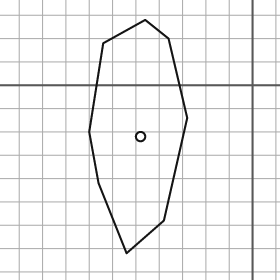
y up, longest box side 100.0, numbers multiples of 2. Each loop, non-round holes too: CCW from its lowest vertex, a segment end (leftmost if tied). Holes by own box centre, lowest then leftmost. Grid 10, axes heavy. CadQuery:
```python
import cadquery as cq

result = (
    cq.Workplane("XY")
    .moveTo(-54.0, -72.0)
    .lineTo(-38.0, -58.0)
    .lineTo(-28.0, -14.0)
    .lineTo(-36.0, 20.0)
    .lineTo(-46.0, 28.0)
    .lineTo(-64.0, 18.0)
    .lineTo(-70.0, -20.0)
    .lineTo(-66.0, -42.0)
    .close()
    .moveTo(-48.0, -22.0)
    .circle(2.0)
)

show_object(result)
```